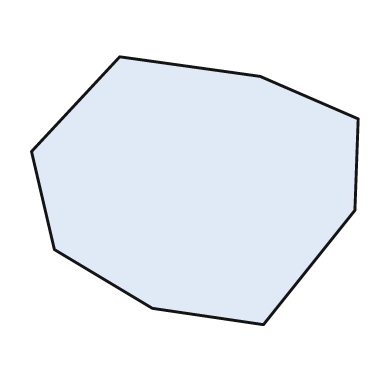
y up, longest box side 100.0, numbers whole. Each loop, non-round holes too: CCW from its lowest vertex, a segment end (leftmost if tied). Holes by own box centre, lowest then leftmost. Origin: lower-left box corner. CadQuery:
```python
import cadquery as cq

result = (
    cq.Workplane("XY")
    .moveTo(71.0, 0.0)
    .lineTo(99.0, 35.0)
    .lineTo(100.0, 63.0)
    .lineTo(70.0, 76.0)
    .lineTo(27.0, 82.0)
    .lineTo(0.0, 53.0)
    .lineTo(7.0, 23.0)
    .lineTo(37.0, 5.0)
    .close()
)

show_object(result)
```